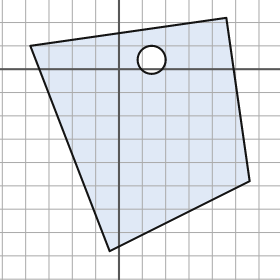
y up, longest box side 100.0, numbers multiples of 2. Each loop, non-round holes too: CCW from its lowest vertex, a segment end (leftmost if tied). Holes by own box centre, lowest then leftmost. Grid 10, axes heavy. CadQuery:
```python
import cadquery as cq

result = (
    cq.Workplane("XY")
    .moveTo(-4.0, -78.0)
    .lineTo(56.0, -48.0)
    .lineTo(46.0, 22.0)
    .lineTo(-38.0, 10.0)
    .close()
    .moveTo(14.0, 4.0)
    .circle(6.0)
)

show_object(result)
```